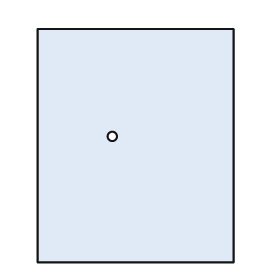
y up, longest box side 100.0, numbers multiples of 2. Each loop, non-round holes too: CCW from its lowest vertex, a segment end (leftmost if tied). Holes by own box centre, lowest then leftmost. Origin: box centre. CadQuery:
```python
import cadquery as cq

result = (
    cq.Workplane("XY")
    .moveTo(-42.0, -50.0)
    .lineTo(42.0, -50.0)
    .lineTo(42.0, 50.0)
    .lineTo(-42.0, 50.0)
    .close()
    .moveTo(-10.0, 4.0)
    .circle(2.0)
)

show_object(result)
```